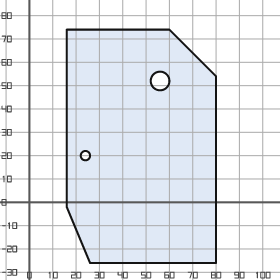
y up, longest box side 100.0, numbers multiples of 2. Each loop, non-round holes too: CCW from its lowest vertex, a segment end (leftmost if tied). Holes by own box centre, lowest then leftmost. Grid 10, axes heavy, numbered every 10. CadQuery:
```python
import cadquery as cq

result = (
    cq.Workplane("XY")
    .moveTo(26.0, -26.0)
    .lineTo(80.0, -26.0)
    .lineTo(80.0, 54.0)
    .lineTo(60.0, 74.0)
    .lineTo(16.0, 74.0)
    .lineTo(16.0, -2.0)
    .close()
    .moveTo(24.0, 20.0)
    .circle(2.0)
    .moveTo(56.0, 52.0)
    .circle(4.0)
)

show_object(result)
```